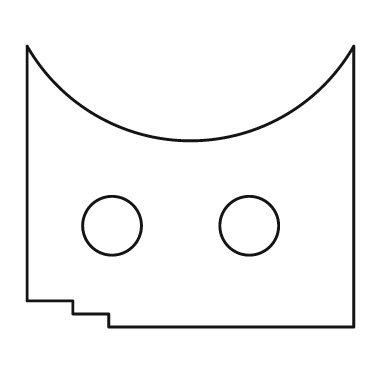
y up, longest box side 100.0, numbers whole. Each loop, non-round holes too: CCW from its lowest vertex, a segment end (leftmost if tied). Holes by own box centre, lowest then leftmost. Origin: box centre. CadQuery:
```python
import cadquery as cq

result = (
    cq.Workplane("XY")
    .moveTo(-25.0, -43.0)
    .lineTo(50.0, -43.0)
    .lineTo(50.0, 43.0)
    .threePointArc((0.0, 14.0), (-50.0, 43.0))
    .lineTo(-50.0, -35.0)
    .lineTo(-36.0, -35.0)
    .lineTo(-36.0, -39.0)
    .lineTo(-25.0, -39.0)
    .close()
    .moveTo(-24.0, -12.0)
    .circle(9.0)
    .moveTo(18.0, -12.0)
    .circle(9.0)
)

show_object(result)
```